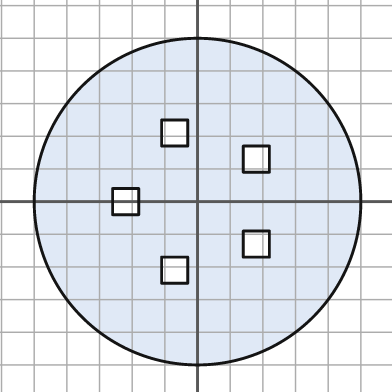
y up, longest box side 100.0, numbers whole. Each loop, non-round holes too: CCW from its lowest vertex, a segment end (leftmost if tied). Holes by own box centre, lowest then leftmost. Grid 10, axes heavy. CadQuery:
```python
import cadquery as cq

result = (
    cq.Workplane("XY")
    .moveTo(0.0, 0.0)
    .circle(50.0)
    .moveTo(-11.0, -25.0)
    .lineTo(-3.0, -25.0)
    .lineTo(-3.0, -17.0)
    .lineTo(-11.0, -17.0)
    .close()
    .moveTo(14.0, -17.0)
    .lineTo(22.0, -17.0)
    .lineTo(22.0, -9.0)
    .lineTo(14.0, -9.0)
    .close()
    .moveTo(-26.0, -4.0)
    .lineTo(-18.0, -4.0)
    .lineTo(-18.0, 4.0)
    .lineTo(-26.0, 4.0)
    .close()
    .moveTo(14.0, 9.0)
    .lineTo(22.0, 9.0)
    .lineTo(22.0, 17.0)
    .lineTo(14.0, 17.0)
    .close()
    .moveTo(-11.0, 17.0)
    .lineTo(-3.0, 17.0)
    .lineTo(-3.0, 25.0)
    .lineTo(-11.0, 25.0)
    .close()
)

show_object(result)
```